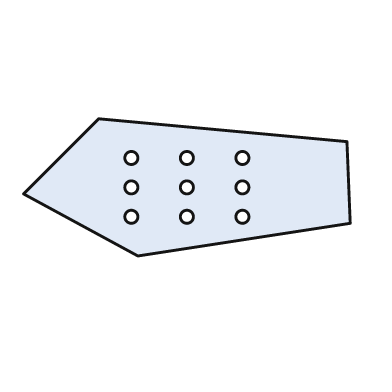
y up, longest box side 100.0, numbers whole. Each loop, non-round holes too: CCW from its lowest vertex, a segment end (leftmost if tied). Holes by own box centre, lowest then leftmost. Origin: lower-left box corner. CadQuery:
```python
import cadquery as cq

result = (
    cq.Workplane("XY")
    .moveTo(35.0, 0.0)
    .lineTo(100.0, 10.0)
    .lineTo(99.0, 35.0)
    .lineTo(23.0, 42.0)
    .lineTo(0.0, 19.0)
    .close()
    .moveTo(33.0, 12.0)
    .circle(2.0)
    .moveTo(50.0, 12.0)
    .circle(2.0)
    .moveTo(67.0, 12.0)
    .circle(2.0)
    .moveTo(33.0, 21.0)
    .circle(2.0)
    .moveTo(50.0, 21.0)
    .circle(2.0)
    .moveTo(67.0, 21.0)
    .circle(2.0)
    .moveTo(33.0, 30.0)
    .circle(2.0)
    .moveTo(50.0, 30.0)
    .circle(2.0)
    .moveTo(67.0, 30.0)
    .circle(2.0)
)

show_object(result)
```